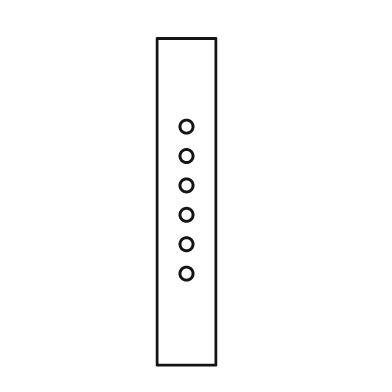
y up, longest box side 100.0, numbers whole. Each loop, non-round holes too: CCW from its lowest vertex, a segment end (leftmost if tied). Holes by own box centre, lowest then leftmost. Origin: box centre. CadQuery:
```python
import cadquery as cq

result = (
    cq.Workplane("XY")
    .moveTo(-9.0, -50.0)
    .lineTo(9.0, -50.0)
    .lineTo(9.0, 50.0)
    .lineTo(-9.0, 50.0)
    .close()
    .moveTo(0.0, -22.0)
    .circle(2.0)
    .moveTo(0.0, -13.0)
    .circle(2.0)
    .moveTo(0.0, -4.0)
    .circle(2.0)
    .moveTo(0.0, 5.0)
    .circle(2.0)
    .moveTo(0.0, 14.0)
    .circle(2.0)
    .moveTo(0.0, 23.0)
    .circle(2.0)
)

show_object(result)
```